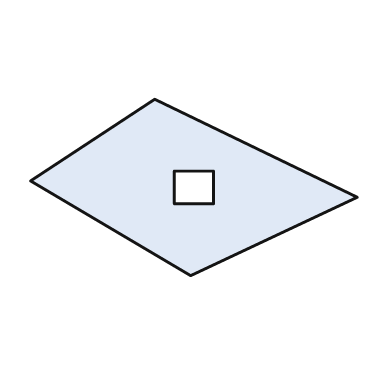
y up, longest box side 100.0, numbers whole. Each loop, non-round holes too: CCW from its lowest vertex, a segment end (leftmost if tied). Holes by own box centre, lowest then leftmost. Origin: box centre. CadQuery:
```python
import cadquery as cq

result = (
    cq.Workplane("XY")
    .moveTo(-1.0, -27.0)
    .lineTo(50.0, -3.0)
    .lineTo(-12.0, 27.0)
    .lineTo(-50.0, 2.0)
    .close()
    .moveTo(-6.0, -5.0)
    .lineTo(6.0, -5.0)
    .lineTo(6.0, 5.0)
    .lineTo(-6.0, 5.0)
    .close()
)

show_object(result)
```